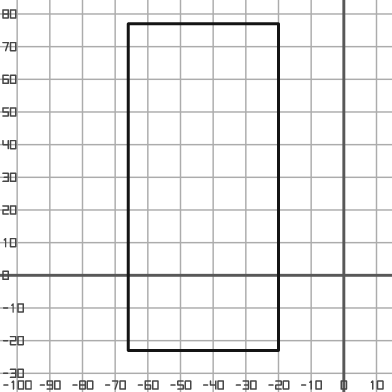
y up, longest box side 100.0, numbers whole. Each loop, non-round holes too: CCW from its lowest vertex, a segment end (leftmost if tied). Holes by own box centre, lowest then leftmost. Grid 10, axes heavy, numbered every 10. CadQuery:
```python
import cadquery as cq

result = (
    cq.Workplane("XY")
    .moveTo(-66.0, -23.0)
    .lineTo(-20.0, -23.0)
    .lineTo(-20.0, 77.0)
    .lineTo(-66.0, 77.0)
    .close()
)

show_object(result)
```